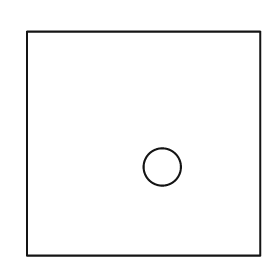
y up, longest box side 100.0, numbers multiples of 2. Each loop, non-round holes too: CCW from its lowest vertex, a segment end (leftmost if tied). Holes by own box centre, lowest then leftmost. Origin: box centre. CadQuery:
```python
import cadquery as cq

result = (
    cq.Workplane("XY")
    .moveTo(-50.0, -48.0)
    .lineTo(50.0, -48.0)
    .lineTo(50.0, 48.0)
    .lineTo(-50.0, 48.0)
    .close()
    .moveTo(8.0, -10.0)
    .circle(8.0)
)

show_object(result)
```